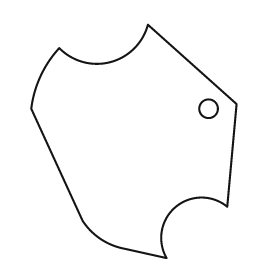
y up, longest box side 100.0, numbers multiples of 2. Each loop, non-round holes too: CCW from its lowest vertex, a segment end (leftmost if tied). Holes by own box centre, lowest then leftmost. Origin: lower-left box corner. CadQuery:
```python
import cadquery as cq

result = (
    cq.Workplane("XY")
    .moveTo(58.0, 0.0)
    .threePointArc((62.0, 22.0), (84.0, 22.0))
    .lineTo(88.0, 66.0)
    .lineTo(50.0, 100.0)
    .threePointArc((34.0, 84.0), (12.0, 90.0))
    .threePointArc((4.0, 78.0), (0.0, 64.0))
    .lineTo(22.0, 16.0)
    .threePointArc((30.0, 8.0), (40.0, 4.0))
    .close()
    .moveTo(76.0, 64.0)
    .circle(4.0)
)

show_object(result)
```